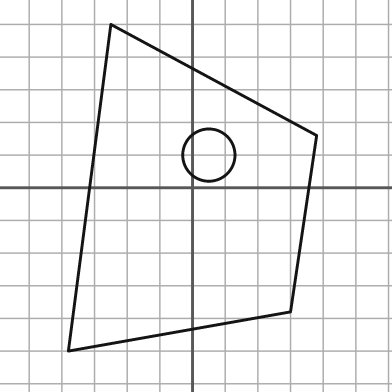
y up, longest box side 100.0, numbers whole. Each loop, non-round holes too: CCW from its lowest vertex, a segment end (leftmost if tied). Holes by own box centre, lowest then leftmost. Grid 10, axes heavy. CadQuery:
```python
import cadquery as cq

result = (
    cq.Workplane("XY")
    .moveTo(-38.0, -50.0)
    .lineTo(30.0, -38.0)
    .lineTo(38.0, 16.0)
    .lineTo(-25.0, 50.0)
    .close()
    .moveTo(5.0, 10.0)
    .circle(8.0)
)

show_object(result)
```